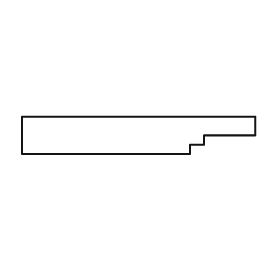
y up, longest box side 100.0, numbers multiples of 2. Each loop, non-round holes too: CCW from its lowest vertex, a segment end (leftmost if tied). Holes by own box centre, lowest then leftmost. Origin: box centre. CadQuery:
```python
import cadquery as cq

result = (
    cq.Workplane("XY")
    .moveTo(-50.0, -8.0)
    .lineTo(22.0, -8.0)
    .lineTo(22.0, -4.0)
    .lineTo(28.0, -4.0)
    .lineTo(28.0, 0.0)
    .lineTo(50.0, 0.0)
    .lineTo(50.0, 8.0)
    .lineTo(-50.0, 8.0)
    .close()
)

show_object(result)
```